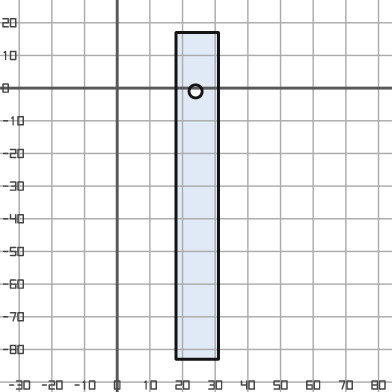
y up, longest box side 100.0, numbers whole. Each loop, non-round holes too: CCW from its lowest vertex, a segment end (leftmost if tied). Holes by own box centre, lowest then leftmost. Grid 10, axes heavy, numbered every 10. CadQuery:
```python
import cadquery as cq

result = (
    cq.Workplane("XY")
    .moveTo(18.0, -83.0)
    .lineTo(31.0, -83.0)
    .lineTo(31.0, 17.0)
    .lineTo(18.0, 17.0)
    .close()
    .moveTo(24.0, -1.0)
    .circle(2.0)
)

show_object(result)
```